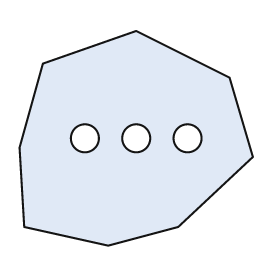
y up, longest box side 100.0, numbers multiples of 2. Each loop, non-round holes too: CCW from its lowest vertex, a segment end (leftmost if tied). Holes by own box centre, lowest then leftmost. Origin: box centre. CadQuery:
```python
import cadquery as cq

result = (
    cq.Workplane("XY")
    .moveTo(-12.0, -46.0)
    .lineTo(18.0, -38.0)
    .lineTo(50.0, -8.0)
    .lineTo(40.0, 26.0)
    .lineTo(0.0, 46.0)
    .lineTo(-40.0, 32.0)
    .lineTo(-50.0, -4.0)
    .lineTo(-48.0, -38.0)
    .close()
    .moveTo(-22.0, 0.0)
    .circle(6.0)
    .moveTo(0.0, 0.0)
    .circle(6.0)
    .moveTo(22.0, 0.0)
    .circle(6.0)
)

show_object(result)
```